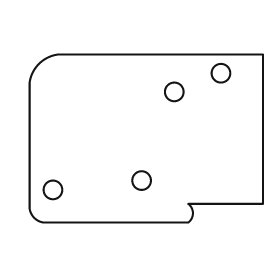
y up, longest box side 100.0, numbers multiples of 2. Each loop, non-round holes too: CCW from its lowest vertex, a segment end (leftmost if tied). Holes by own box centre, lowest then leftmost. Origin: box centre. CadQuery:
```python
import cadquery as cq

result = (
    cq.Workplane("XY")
    .moveTo(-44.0, -36.0)
    .lineTo(18.0, -36.0)
    .threePointArc((20.0, -32.0), (18.0, -28.0))
    .lineTo(50.0, -28.0)
    .lineTo(50.0, 36.0)
    .lineTo(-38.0, 36.0)
    .threePointArc((-46.0, 32.0), (-50.0, 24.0))
    .lineTo(-50.0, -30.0)
    .threePointArc((-48.0, -34.0), (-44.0, -36.0))
    .close()
    .moveTo(-40.0, -22.0)
    .circle(4.0)
    .moveTo(-2.0, -18.0)
    .circle(4.0)
    .moveTo(12.0, 20.0)
    .circle(4.0)
    .moveTo(32.0, 28.0)
    .circle(4.0)
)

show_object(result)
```